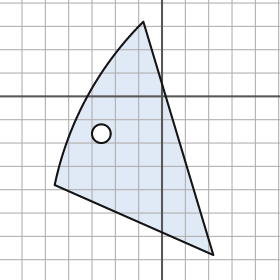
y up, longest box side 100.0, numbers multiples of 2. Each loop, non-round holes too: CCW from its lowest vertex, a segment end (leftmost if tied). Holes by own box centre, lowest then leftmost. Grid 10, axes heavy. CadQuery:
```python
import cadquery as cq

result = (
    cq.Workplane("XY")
    .moveTo(22.0, -68.0)
    .lineTo(-8.0, 32.0)
    .threePointArc((-32.0, 0.0), (-46.0, -38.0))
    .close()
    .moveTo(-26.0, -16.0)
    .circle(4.0)
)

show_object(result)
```